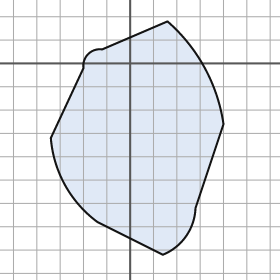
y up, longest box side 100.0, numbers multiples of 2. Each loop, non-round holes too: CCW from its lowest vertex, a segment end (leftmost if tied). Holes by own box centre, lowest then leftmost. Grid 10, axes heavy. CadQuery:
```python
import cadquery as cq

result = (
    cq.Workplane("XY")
    .moveTo(14.0, -82.0)
    .threePointArc((24.0, -74.0), (28.0, -62.0))
    .lineTo(40.0, -26.0)
    .threePointArc((32.0, -2.0), (16.0, 18.0))
    .lineTo(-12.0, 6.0)
    .threePointArc((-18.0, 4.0), (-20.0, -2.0))
    .lineTo(-34.0, -32.0)
    .threePointArc((-28.0, -52.0), (-14.0, -68.0))
    .close()
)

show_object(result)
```